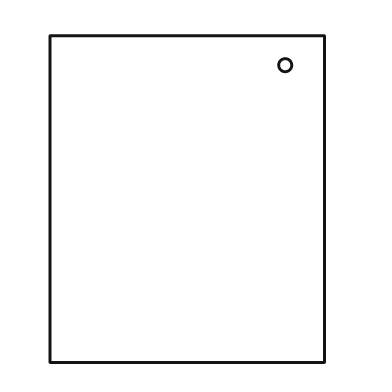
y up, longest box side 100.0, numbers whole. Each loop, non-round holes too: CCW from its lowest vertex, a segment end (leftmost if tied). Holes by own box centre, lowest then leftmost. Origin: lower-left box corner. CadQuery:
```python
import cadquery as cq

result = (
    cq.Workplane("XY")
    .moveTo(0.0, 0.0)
    .lineTo(84.0, 0.0)
    .lineTo(84.0, 100.0)
    .lineTo(0.0, 100.0)
    .close()
    .moveTo(72.0, 91.0)
    .circle(2.0)
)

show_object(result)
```